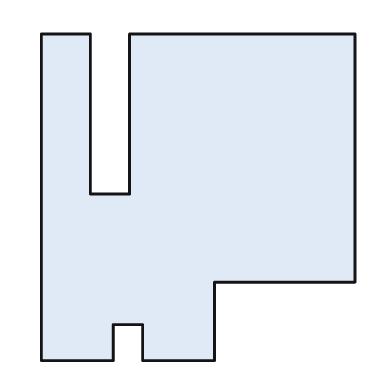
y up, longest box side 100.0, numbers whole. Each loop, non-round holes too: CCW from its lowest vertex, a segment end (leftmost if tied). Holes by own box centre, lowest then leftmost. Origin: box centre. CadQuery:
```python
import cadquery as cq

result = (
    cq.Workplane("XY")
    .moveTo(-48.0, -50.0)
    .lineTo(-26.0, -50.0)
    .lineTo(-26.0, -39.0)
    .lineTo(-17.0, -39.0)
    .lineTo(-17.0, -50.0)
    .lineTo(5.0, -50.0)
    .lineTo(5.0, -26.0)
    .lineTo(48.0, -26.0)
    .lineTo(48.0, 50.0)
    .lineTo(-21.0, 50.0)
    .lineTo(-21.0, 1.0)
    .lineTo(-33.0, 1.0)
    .lineTo(-33.0, 50.0)
    .lineTo(-48.0, 50.0)
    .close()
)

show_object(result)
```